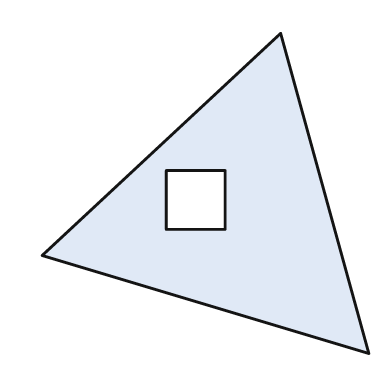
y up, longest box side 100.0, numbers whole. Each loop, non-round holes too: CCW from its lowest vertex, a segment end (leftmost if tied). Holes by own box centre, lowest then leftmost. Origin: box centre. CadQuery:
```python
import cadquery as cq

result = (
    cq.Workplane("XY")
    .moveTo(50.0, -49.0)
    .lineTo(23.0, 49.0)
    .lineTo(-50.0, -19.0)
    .close()
    .moveTo(-12.0, -11.0)
    .lineTo(6.0, -11.0)
    .lineTo(6.0, 7.0)
    .lineTo(-12.0, 7.0)
    .close()
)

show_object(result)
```